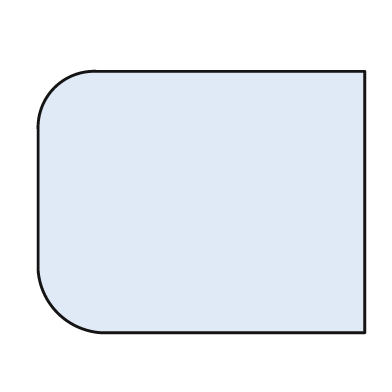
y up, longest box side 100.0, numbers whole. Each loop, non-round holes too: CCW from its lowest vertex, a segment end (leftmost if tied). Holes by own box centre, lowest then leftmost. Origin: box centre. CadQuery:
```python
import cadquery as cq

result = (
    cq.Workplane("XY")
    .moveTo(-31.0, -40.0)
    .lineTo(50.0, -40.0)
    .lineTo(50.0, 40.0)
    .lineTo(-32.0, 40.0)
    .threePointArc((-45.0, 35.0), (-50.0, 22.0))
    .lineTo(-50.0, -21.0)
    .threePointArc((-44.0, -34.0), (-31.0, -40.0))
    .close()
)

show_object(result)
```